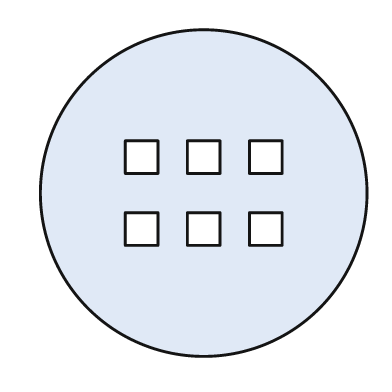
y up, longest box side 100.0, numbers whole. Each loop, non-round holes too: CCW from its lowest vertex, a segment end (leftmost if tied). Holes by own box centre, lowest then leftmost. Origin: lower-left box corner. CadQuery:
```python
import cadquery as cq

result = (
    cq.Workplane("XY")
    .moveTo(50.0, 50.0)
    .circle(50.0)
    .moveTo(26.0, 34.0)
    .lineTo(36.0, 34.0)
    .lineTo(36.0, 44.0)
    .lineTo(26.0, 44.0)
    .close()
    .moveTo(45.0, 34.0)
    .lineTo(55.0, 34.0)
    .lineTo(55.0, 44.0)
    .lineTo(45.0, 44.0)
    .close()
    .moveTo(64.0, 34.0)
    .lineTo(74.0, 34.0)
    .lineTo(74.0, 44.0)
    .lineTo(64.0, 44.0)
    .close()
    .moveTo(26.0, 56.0)
    .lineTo(36.0, 56.0)
    .lineTo(36.0, 66.0)
    .lineTo(26.0, 66.0)
    .close()
    .moveTo(45.0, 56.0)
    .lineTo(55.0, 56.0)
    .lineTo(55.0, 66.0)
    .lineTo(45.0, 66.0)
    .close()
    .moveTo(64.0, 56.0)
    .lineTo(74.0, 56.0)
    .lineTo(74.0, 66.0)
    .lineTo(64.0, 66.0)
    .close()
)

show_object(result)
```